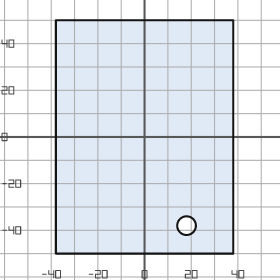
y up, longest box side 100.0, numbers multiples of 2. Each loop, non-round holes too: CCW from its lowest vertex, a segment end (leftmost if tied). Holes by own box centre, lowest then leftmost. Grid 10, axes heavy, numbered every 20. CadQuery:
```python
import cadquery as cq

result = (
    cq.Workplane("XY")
    .moveTo(-38.0, -50.0)
    .lineTo(38.0, -50.0)
    .lineTo(38.0, 50.0)
    .lineTo(-38.0, 50.0)
    .close()
    .moveTo(18.0, -38.0)
    .circle(4.0)
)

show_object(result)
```